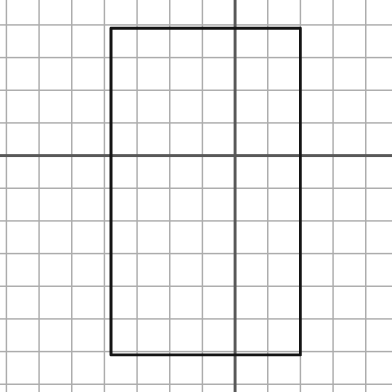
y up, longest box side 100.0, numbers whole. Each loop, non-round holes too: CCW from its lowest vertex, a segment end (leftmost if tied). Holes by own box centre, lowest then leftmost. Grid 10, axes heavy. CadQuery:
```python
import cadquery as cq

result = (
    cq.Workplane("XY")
    .moveTo(-38.0, -61.0)
    .lineTo(20.0, -61.0)
    .lineTo(20.0, 39.0)
    .lineTo(-38.0, 39.0)
    .close()
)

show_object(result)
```